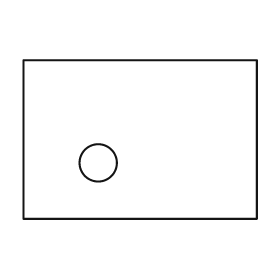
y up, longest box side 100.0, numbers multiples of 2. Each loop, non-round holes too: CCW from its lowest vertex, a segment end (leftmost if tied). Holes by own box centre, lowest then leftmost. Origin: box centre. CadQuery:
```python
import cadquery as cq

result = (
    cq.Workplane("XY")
    .moveTo(-50.0, -34.0)
    .lineTo(50.0, -34.0)
    .lineTo(50.0, 34.0)
    .lineTo(-50.0, 34.0)
    .close()
    .moveTo(-18.0, -10.0)
    .circle(8.0)
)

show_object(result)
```